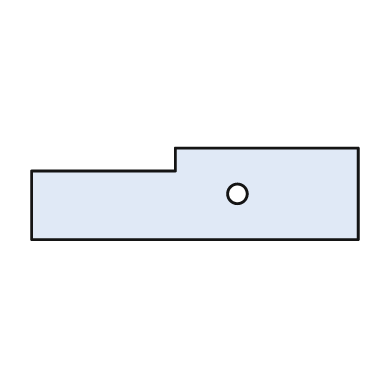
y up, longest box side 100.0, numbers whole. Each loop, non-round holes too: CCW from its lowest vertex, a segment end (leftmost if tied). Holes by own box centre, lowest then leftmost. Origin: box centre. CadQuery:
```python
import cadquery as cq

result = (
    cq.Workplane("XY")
    .moveTo(-50.0, -14.0)
    .lineTo(50.0, -14.0)
    .lineTo(50.0, 14.0)
    .lineTo(-6.0, 14.0)
    .lineTo(-6.0, 7.0)
    .lineTo(-50.0, 7.0)
    .close()
    .moveTo(13.0, 0.0)
    .circle(3.0)
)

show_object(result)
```